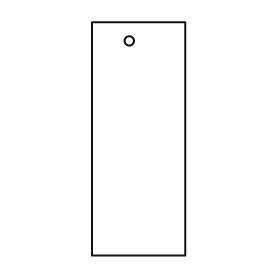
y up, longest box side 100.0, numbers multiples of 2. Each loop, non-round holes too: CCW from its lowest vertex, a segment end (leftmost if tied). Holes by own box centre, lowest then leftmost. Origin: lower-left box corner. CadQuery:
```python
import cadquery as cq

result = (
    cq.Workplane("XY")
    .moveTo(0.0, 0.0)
    .lineTo(40.0, 0.0)
    .lineTo(40.0, 100.0)
    .lineTo(0.0, 100.0)
    .close()
    .moveTo(16.0, 92.0)
    .circle(2.0)
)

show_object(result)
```